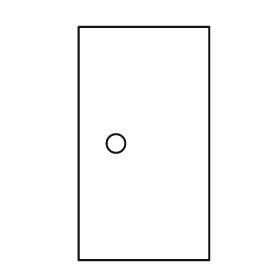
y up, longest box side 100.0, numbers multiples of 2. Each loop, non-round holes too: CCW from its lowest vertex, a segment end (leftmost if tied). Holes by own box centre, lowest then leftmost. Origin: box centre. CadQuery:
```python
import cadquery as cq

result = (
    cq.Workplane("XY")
    .moveTo(-28.0, -50.0)
    .lineTo(28.0, -50.0)
    .lineTo(28.0, 50.0)
    .lineTo(-28.0, 50.0)
    .close()
    .moveTo(-12.0, 0.0)
    .circle(4.0)
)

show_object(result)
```